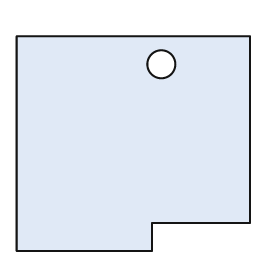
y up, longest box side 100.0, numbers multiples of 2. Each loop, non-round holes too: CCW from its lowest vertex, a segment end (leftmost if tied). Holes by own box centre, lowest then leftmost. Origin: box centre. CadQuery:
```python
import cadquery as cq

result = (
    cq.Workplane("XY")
    .moveTo(-50.0, -46.0)
    .lineTo(8.0, -46.0)
    .lineTo(8.0, -34.0)
    .lineTo(50.0, -34.0)
    .lineTo(50.0, 46.0)
    .lineTo(-50.0, 46.0)
    .close()
    .moveTo(12.0, 34.0)
    .circle(6.0)
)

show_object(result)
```